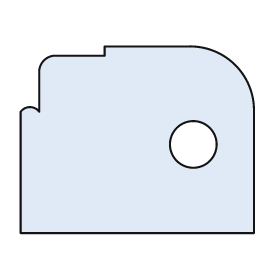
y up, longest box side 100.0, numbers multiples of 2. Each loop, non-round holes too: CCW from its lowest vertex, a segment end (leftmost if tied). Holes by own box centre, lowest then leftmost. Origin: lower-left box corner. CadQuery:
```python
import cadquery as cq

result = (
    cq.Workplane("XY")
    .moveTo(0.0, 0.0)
    .lineTo(100.0, 0.0)
    .lineTo(100.0, 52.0)
    .threePointArc((92.0, 72.0), (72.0, 80.0))
    .lineTo(36.0, 80.0)
    .lineTo(36.0, 76.0)
    .lineTo(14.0, 76.0)
    .threePointArc((10.0, 74.0), (8.0, 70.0))
    .lineTo(8.0, 52.0)
    .threePointArc((4.0, 54.0), (0.0, 52.0))
    .close()
    .moveTo(74.0, 38.0)
    .circle(10.0)
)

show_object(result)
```